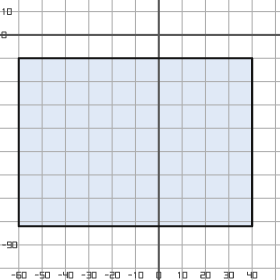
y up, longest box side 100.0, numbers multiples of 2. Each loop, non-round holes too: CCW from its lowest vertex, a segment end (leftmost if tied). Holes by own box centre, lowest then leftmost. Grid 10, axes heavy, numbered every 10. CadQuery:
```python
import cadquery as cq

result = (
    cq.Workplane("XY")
    .moveTo(-60.0, -82.0)
    .lineTo(40.0, -82.0)
    .lineTo(40.0, -10.0)
    .lineTo(-60.0, -10.0)
    .close()
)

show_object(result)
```